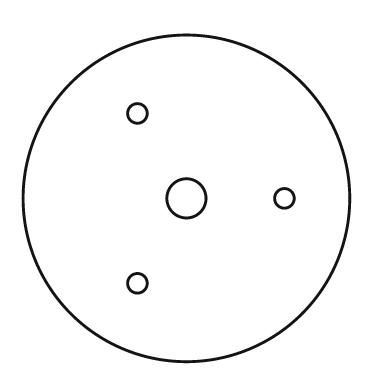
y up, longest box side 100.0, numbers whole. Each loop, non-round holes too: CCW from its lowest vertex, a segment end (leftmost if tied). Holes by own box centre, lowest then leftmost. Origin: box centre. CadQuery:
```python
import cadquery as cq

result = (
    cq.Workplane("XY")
    .moveTo(0.0, 0.0)
    .circle(50.0)
    .moveTo(-15.0, -26.0)
    .circle(3.0)
    .moveTo(0.0, 0.0)
    .circle(6.0)
    .moveTo(30.0, 0.0)
    .circle(3.0)
    .moveTo(-15.0, 26.0)
    .circle(3.0)
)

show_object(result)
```